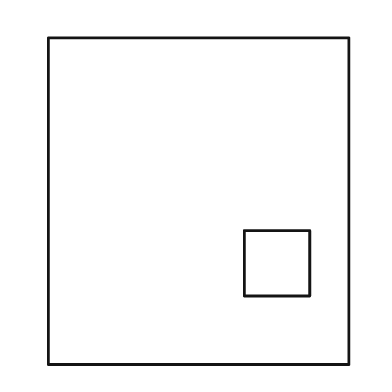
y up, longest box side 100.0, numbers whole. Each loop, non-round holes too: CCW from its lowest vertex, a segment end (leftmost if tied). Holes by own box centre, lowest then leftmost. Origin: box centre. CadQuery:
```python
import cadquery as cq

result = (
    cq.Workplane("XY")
    .moveTo(-46.0, -50.0)
    .lineTo(46.0, -50.0)
    .lineTo(46.0, 50.0)
    .lineTo(-46.0, 50.0)
    .close()
    .moveTo(14.0, -29.0)
    .lineTo(34.0, -29.0)
    .lineTo(34.0, -9.0)
    .lineTo(14.0, -9.0)
    .close()
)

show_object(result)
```